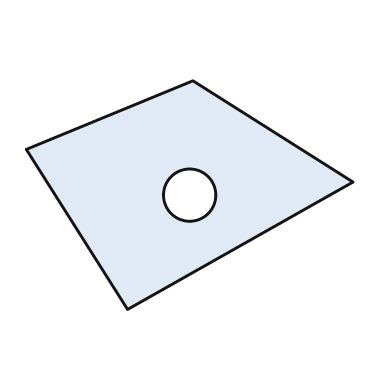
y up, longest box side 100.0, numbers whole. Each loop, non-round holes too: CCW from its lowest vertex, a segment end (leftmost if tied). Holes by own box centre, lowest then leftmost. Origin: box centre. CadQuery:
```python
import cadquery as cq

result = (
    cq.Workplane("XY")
    .moveTo(-19.0, -35.0)
    .lineTo(50.0, 4.0)
    .lineTo(1.0, 35.0)
    .lineTo(-50.0, 14.0)
    .close()
    .moveTo(0.0, 0.0)
    .circle(8.0)
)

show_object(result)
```